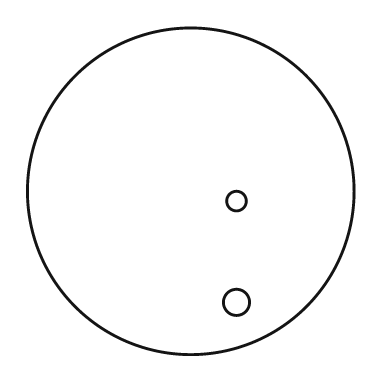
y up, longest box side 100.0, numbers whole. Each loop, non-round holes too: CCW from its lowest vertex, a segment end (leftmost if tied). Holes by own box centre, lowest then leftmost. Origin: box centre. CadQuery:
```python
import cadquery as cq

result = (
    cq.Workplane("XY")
    .moveTo(0.0, 0.0)
    .circle(50.0)
    .moveTo(14.0, -34.0)
    .circle(4.0)
    .moveTo(14.0, -3.0)
    .circle(3.0)
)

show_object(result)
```